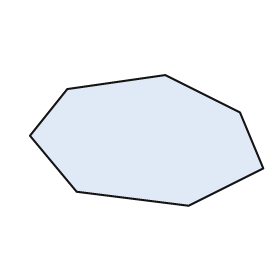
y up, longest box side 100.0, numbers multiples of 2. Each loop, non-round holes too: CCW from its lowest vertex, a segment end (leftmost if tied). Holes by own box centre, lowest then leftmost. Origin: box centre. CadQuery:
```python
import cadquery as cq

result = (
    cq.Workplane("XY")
    .moveTo(18.0, -28.0)
    .lineTo(50.0, -12.0)
    .lineTo(40.0, 12.0)
    .lineTo(8.0, 28.0)
    .lineTo(-34.0, 22.0)
    .lineTo(-50.0, 2.0)
    .lineTo(-30.0, -22.0)
    .close()
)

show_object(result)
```